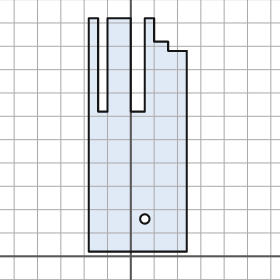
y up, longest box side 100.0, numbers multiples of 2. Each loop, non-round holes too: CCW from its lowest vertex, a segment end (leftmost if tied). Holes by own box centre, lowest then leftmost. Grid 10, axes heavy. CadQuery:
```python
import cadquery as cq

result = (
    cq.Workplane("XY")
    .moveTo(-18.0, 2.0)
    .lineTo(24.0, 2.0)
    .lineTo(24.0, 88.0)
    .lineTo(16.0, 88.0)
    .lineTo(16.0, 92.0)
    .lineTo(10.0, 92.0)
    .lineTo(10.0, 102.0)
    .lineTo(6.0, 102.0)
    .lineTo(6.0, 62.0)
    .lineTo(0.0, 62.0)
    .lineTo(0.0, 102.0)
    .lineTo(-10.0, 102.0)
    .lineTo(-10.0, 62.0)
    .lineTo(-14.0, 62.0)
    .lineTo(-14.0, 102.0)
    .lineTo(-18.0, 102.0)
    .close()
    .moveTo(6.0, 16.0)
    .circle(2.0)
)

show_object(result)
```